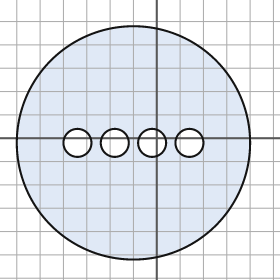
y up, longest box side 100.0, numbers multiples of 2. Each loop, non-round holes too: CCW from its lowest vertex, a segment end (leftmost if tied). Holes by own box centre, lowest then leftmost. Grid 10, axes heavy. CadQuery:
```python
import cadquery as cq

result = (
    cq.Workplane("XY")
    .moveTo(-10.0, -2.0)
    .circle(50.0)
    .moveTo(-34.0, -2.0)
    .circle(6.0)
    .moveTo(-18.0, -2.0)
    .circle(6.0)
    .moveTo(-2.0, -2.0)
    .circle(6.0)
    .moveTo(14.0, -2.0)
    .circle(6.0)
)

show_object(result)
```